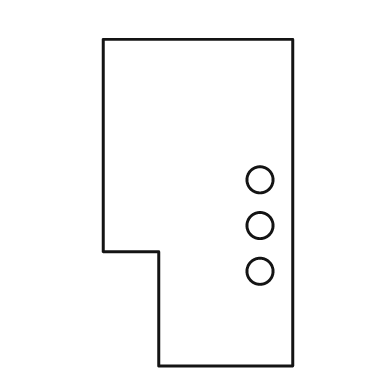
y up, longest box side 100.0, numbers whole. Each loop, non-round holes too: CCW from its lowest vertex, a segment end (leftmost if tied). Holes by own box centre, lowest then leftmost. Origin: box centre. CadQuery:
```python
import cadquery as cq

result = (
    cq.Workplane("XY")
    .moveTo(-12.0, -50.0)
    .lineTo(29.0, -50.0)
    .lineTo(29.0, 50.0)
    .lineTo(-29.0, 50.0)
    .lineTo(-29.0, -15.0)
    .lineTo(-12.0, -15.0)
    .close()
    .moveTo(19.0, -21.0)
    .circle(4.0)
    .moveTo(19.0, -7.0)
    .circle(4.0)
    .moveTo(19.0, 7.0)
    .circle(4.0)
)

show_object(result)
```